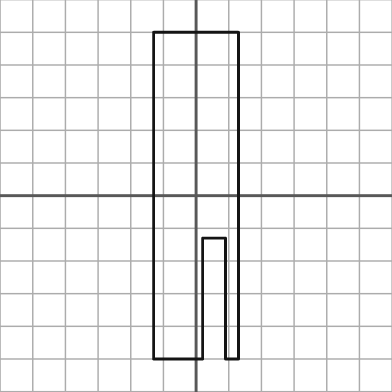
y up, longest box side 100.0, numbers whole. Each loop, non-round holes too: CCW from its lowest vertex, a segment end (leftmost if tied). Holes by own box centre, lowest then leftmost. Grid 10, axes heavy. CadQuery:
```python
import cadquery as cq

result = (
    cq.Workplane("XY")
    .moveTo(-13.0, -50.0)
    .lineTo(2.0, -50.0)
    .lineTo(2.0, -13.0)
    .lineTo(9.0, -13.0)
    .lineTo(9.0, -50.0)
    .lineTo(13.0, -50.0)
    .lineTo(13.0, 50.0)
    .lineTo(-13.0, 50.0)
    .close()
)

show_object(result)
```